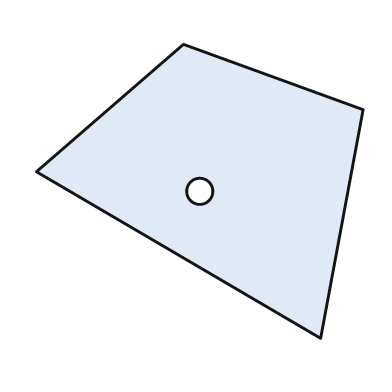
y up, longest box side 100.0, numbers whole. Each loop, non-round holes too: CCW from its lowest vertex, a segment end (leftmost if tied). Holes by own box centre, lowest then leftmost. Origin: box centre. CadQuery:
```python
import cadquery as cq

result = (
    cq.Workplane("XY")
    .moveTo(37.0, -45.0)
    .lineTo(50.0, 25.0)
    .lineTo(-5.0, 45.0)
    .lineTo(-50.0, 6.0)
    .close()
    .moveTo(0.0, 0.0)
    .circle(4.0)
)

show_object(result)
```